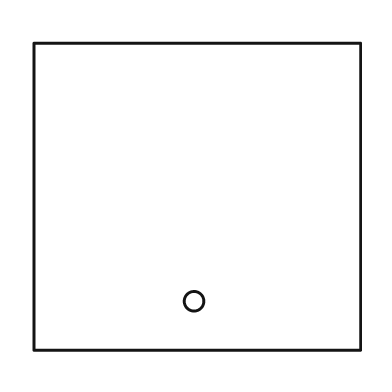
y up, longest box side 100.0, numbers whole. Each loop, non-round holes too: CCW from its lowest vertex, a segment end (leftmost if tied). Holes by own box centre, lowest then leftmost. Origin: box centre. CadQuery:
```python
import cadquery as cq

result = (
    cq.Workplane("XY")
    .moveTo(-50.0, -47.0)
    .lineTo(50.0, -47.0)
    .lineTo(50.0, 47.0)
    .lineTo(-50.0, 47.0)
    .close()
    .moveTo(-1.0, -32.0)
    .circle(3.0)
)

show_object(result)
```